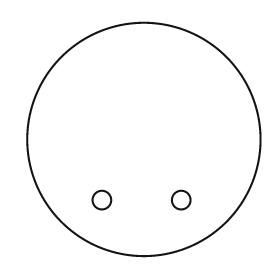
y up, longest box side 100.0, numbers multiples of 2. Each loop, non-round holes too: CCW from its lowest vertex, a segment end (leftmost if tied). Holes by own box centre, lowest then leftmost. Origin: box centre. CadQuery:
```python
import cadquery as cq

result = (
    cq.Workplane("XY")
    .moveTo(0.0, 0.0)
    .circle(50.0)
    .moveTo(-18.0, -26.0)
    .circle(4.0)
    .moveTo(16.0, -26.0)
    .circle(4.0)
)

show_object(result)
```